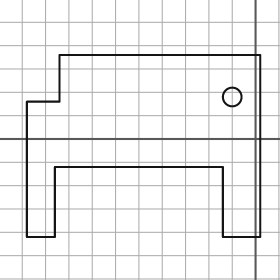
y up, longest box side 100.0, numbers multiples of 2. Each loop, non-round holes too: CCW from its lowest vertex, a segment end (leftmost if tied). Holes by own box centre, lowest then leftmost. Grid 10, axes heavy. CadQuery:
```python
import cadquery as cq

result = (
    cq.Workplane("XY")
    .moveTo(-98.0, -42.0)
    .lineTo(-86.0, -42.0)
    .lineTo(-86.0, -12.0)
    .lineTo(-14.0, -12.0)
    .lineTo(-14.0, -42.0)
    .lineTo(2.0, -42.0)
    .lineTo(2.0, 36.0)
    .lineTo(-84.0, 36.0)
    .lineTo(-84.0, 16.0)
    .lineTo(-98.0, 16.0)
    .close()
    .moveTo(-10.0, 18.0)
    .circle(4.0)
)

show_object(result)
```